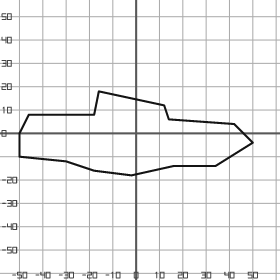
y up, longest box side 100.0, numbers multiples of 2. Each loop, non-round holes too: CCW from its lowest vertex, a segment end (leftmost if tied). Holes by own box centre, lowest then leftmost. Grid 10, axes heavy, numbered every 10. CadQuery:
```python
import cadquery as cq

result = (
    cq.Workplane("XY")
    .moveTo(-2.0, -18.0)
    .lineTo(16.0, -14.0)
    .lineTo(34.0, -14.0)
    .lineTo(50.0, -4.0)
    .lineTo(42.0, 4.0)
    .lineTo(14.0, 6.0)
    .lineTo(12.0, 12.0)
    .lineTo(-16.0, 18.0)
    .lineTo(-18.0, 8.0)
    .lineTo(-46.0, 8.0)
    .lineTo(-50.0, 0.0)
    .lineTo(-50.0, -10.0)
    .lineTo(-30.0, -12.0)
    .lineTo(-18.0, -16.0)
    .close()
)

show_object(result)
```